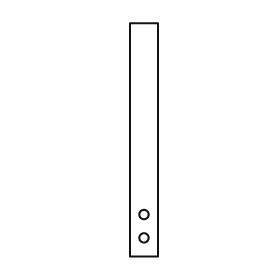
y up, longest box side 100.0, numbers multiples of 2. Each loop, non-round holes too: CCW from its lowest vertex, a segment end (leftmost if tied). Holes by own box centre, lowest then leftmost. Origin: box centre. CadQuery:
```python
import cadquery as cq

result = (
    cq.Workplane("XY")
    .moveTo(-6.0, -50.0)
    .lineTo(6.0, -50.0)
    .lineTo(6.0, 50.0)
    .lineTo(-6.0, 50.0)
    .close()
    .moveTo(0.0, -42.0)
    .circle(2.0)
    .moveTo(0.0, -32.0)
    .circle(2.0)
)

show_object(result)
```